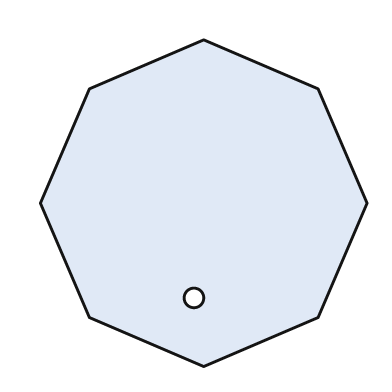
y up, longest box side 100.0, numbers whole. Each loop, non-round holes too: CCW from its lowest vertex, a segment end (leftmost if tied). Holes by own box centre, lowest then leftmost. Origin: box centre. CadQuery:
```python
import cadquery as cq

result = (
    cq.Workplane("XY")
    .moveTo(0.0, -50.0)
    .lineTo(35.0, -35.0)
    .lineTo(50.0, 0.0)
    .lineTo(35.0, 35.0)
    .lineTo(0.0, 50.0)
    .lineTo(-35.0, 35.0)
    .lineTo(-50.0, 0.0)
    .lineTo(-35.0, -35.0)
    .close()
    .moveTo(-3.0, -29.0)
    .circle(3.0)
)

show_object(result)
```